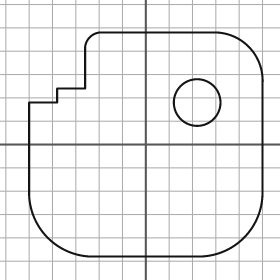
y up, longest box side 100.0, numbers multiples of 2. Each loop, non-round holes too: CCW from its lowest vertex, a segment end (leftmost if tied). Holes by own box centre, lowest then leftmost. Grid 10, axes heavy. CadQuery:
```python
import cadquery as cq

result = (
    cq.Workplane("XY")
    .moveTo(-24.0, -48.0)
    .lineTo(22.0, -48.0)
    .threePointArc((42.0, -40.0), (50.0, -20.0))
    .lineTo(50.0, 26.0)
    .threePointArc((44.0, 42.0), (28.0, 48.0))
    .lineTo(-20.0, 48.0)
    .threePointArc((-24.0, 46.0), (-26.0, 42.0))
    .lineTo(-26.0, 24.0)
    .lineTo(-38.0, 24.0)
    .lineTo(-38.0, 18.0)
    .lineTo(-50.0, 18.0)
    .lineTo(-50.0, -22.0)
    .threePointArc((-42.0, -40.0), (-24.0, -48.0))
    .close()
    .moveTo(22.0, 18.0)
    .circle(10.0)
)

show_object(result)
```